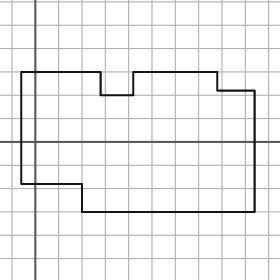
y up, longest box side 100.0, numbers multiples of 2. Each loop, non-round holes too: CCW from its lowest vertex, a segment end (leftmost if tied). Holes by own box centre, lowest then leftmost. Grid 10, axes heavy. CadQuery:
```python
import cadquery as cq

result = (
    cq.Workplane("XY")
    .moveTo(20.0, -30.0)
    .lineTo(94.0, -30.0)
    .lineTo(94.0, 22.0)
    .lineTo(78.0, 22.0)
    .lineTo(78.0, 30.0)
    .lineTo(42.0, 30.0)
    .lineTo(42.0, 20.0)
    .lineTo(28.0, 20.0)
    .lineTo(28.0, 30.0)
    .lineTo(-6.0, 30.0)
    .lineTo(-6.0, -18.0)
    .lineTo(20.0, -18.0)
    .close()
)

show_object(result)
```